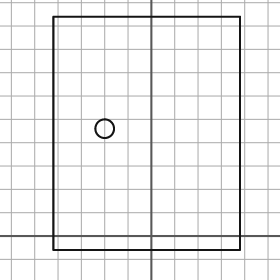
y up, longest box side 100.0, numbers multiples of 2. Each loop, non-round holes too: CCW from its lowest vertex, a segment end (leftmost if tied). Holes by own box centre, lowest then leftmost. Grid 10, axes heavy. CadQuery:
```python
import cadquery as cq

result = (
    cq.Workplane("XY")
    .moveTo(-42.0, -6.0)
    .lineTo(38.0, -6.0)
    .lineTo(38.0, 94.0)
    .lineTo(-42.0, 94.0)
    .close()
    .moveTo(-20.0, 46.0)
    .circle(4.0)
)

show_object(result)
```